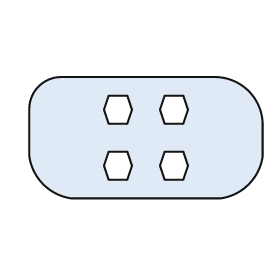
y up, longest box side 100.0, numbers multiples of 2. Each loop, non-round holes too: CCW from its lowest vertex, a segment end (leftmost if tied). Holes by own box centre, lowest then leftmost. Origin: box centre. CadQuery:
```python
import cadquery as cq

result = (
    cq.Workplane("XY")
    .moveTo(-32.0, -26.0)
    .lineTo(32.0, -26.0)
    .threePointArc((44.0, -20.0), (50.0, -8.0))
    .lineTo(50.0, 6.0)
    .threePointArc((44.0, 20.0), (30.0, 26.0))
    .lineTo(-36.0, 26.0)
    .threePointArc((-46.0, 22.0), (-50.0, 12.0))
    .lineTo(-50.0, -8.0)
    .threePointArc((-44.0, -20.0), (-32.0, -26.0))
    .close()
    .moveTo(-16.0, -18.0)
    .lineTo(-8.0, -18.0)
    .lineTo(-6.0, -12.0)
    .lineTo(-8.0, -6.0)
    .lineTo(-16.0, -6.0)
    .lineTo(-18.0, -12.0)
    .close()
    .moveTo(8.0, -18.0)
    .lineTo(16.0, -18.0)
    .lineTo(18.0, -12.0)
    .lineTo(16.0, -6.0)
    .lineTo(8.0, -6.0)
    .lineTo(6.0, -12.0)
    .close()
    .moveTo(-16.0, 6.0)
    .lineTo(-8.0, 6.0)
    .lineTo(-6.0, 12.0)
    .lineTo(-8.0, 18.0)
    .lineTo(-16.0, 18.0)
    .lineTo(-18.0, 12.0)
    .close()
    .moveTo(8.0, 6.0)
    .lineTo(16.0, 6.0)
    .lineTo(18.0, 12.0)
    .lineTo(16.0, 18.0)
    .lineTo(8.0, 18.0)
    .lineTo(6.0, 12.0)
    .close()
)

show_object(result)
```